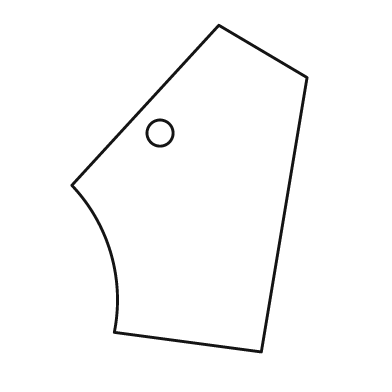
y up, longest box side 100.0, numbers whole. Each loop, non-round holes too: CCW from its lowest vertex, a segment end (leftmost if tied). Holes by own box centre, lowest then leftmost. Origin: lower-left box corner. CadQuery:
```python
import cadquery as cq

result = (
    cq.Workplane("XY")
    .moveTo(58.0, 0.0)
    .lineTo(72.0, 84.0)
    .lineTo(45.0, 100.0)
    .lineTo(0.0, 51.0)
    .threePointArc((12.0, 30.0), (13.0, 6.0))
    .close()
    .moveTo(27.0, 67.0)
    .circle(4.0)
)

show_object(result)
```